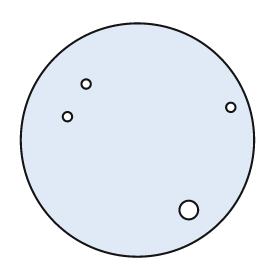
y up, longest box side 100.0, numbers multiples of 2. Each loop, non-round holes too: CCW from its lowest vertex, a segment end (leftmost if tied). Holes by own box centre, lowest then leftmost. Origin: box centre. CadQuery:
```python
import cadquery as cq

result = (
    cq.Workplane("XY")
    .moveTo(0.0, 0.0)
    .circle(50.0)
    .moveTo(22.0, -30.0)
    .circle(4.0)
    .moveTo(-30.0, 10.0)
    .circle(2.0)
    .moveTo(40.0, 14.0)
    .circle(2.0)
    .moveTo(-22.0, 24.0)
    .circle(2.0)
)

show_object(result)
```